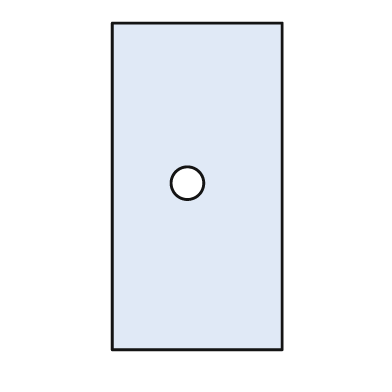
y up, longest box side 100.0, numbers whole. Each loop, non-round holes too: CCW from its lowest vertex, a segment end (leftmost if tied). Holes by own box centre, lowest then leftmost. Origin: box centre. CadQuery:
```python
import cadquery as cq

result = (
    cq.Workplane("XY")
    .moveTo(-26.0, -50.0)
    .lineTo(26.0, -50.0)
    .lineTo(26.0, 50.0)
    .lineTo(-26.0, 50.0)
    .close()
    .moveTo(-3.0, 1.0)
    .circle(5.0)
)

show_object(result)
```